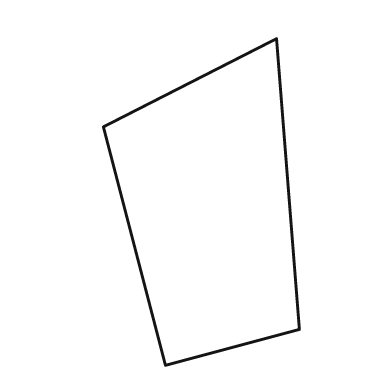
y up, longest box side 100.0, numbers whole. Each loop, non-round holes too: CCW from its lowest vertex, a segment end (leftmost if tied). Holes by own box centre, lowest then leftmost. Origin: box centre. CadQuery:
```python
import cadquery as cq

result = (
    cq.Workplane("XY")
    .moveTo(-11.0, -50.0)
    .lineTo(30.0, -39.0)
    .lineTo(23.0, 50.0)
    .lineTo(-30.0, 23.0)
    .close()
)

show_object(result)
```